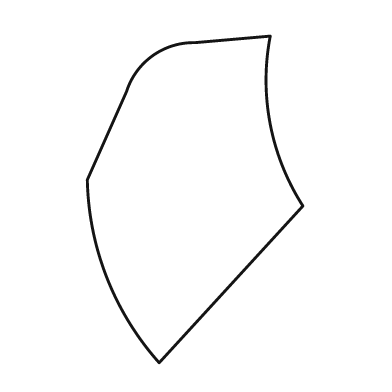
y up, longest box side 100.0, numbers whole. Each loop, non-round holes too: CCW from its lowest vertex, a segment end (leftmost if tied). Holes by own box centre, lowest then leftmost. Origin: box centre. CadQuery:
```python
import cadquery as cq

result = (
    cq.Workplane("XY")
    .moveTo(-11.0, -50.0)
    .lineTo(33.0, -2.0)
    .threePointArc((23.0, 23.0), (23.0, 50.0))
    .lineTo(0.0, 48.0)
    .threePointArc((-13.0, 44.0), (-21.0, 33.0))
    .lineTo(-33.0, 6.0)
    .threePointArc((-27.0, -24.0), (-11.0, -50.0))
    .close()
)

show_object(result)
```